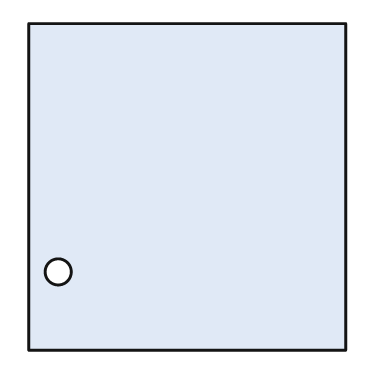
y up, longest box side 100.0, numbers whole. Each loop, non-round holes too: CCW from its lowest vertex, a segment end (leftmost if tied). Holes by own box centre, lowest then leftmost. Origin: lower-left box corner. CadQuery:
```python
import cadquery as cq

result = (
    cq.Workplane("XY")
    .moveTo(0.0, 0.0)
    .lineTo(97.0, 0.0)
    .lineTo(97.0, 100.0)
    .lineTo(0.0, 100.0)
    .close()
    .moveTo(9.0, 24.0)
    .circle(4.0)
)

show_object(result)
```